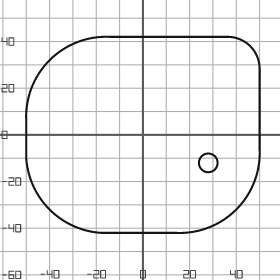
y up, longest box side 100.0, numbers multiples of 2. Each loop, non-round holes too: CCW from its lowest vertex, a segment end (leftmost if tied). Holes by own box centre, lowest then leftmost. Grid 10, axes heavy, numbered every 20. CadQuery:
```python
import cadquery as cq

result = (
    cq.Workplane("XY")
    .moveTo(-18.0, -42.0)
    .lineTo(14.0, -42.0)
    .threePointArc((40.0, -32.0), (50.0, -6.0))
    .lineTo(50.0, 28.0)
    .threePointArc((46.0, 38.0), (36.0, 42.0))
    .lineTo(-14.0, 42.0)
    .threePointArc((-40.0, 32.0), (-50.0, 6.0))
    .lineTo(-50.0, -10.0)
    .threePointArc((-40.0, -32.0), (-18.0, -42.0))
    .close()
    .moveTo(28.0, -12.0)
    .circle(4.0)
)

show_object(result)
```